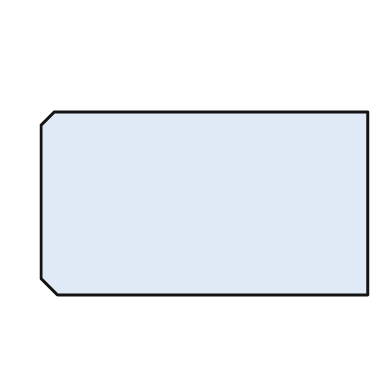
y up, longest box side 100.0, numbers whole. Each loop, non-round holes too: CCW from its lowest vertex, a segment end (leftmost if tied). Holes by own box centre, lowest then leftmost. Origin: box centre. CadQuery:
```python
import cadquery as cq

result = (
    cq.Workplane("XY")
    .moveTo(-45.0, -28.0)
    .lineTo(50.0, -28.0)
    .lineTo(50.0, 28.0)
    .lineTo(-46.0, 28.0)
    .lineTo(-50.0, 24.0)
    .lineTo(-50.0, -23.0)
    .close()
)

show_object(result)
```